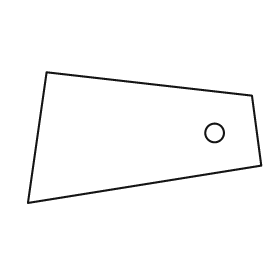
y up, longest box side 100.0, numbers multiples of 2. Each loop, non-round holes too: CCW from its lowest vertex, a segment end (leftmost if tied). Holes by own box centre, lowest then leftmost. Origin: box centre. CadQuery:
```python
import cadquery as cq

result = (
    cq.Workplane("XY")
    .moveTo(-50.0, -28.0)
    .lineTo(50.0, -12.0)
    .lineTo(46.0, 18.0)
    .lineTo(-42.0, 28.0)
    .close()
    .moveTo(30.0, 2.0)
    .circle(4.0)
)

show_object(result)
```